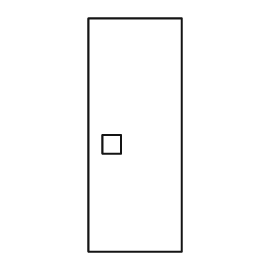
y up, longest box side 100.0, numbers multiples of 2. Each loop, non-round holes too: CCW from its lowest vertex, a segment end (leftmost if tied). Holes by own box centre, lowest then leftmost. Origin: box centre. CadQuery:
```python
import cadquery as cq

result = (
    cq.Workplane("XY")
    .moveTo(-20.0, -50.0)
    .lineTo(20.0, -50.0)
    .lineTo(20.0, 50.0)
    .lineTo(-20.0, 50.0)
    .close()
    .moveTo(-14.0, -8.0)
    .lineTo(-6.0, -8.0)
    .lineTo(-6.0, 0.0)
    .lineTo(-14.0, 0.0)
    .close()
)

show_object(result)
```